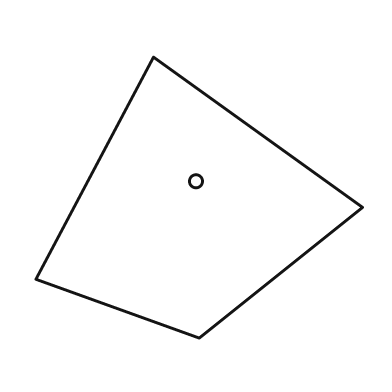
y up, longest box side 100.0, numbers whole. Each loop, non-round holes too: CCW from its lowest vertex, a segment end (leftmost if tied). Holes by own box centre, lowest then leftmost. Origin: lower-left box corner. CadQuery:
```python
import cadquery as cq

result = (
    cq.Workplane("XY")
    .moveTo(50.0, 0.0)
    .lineTo(100.0, 40.0)
    .lineTo(36.0, 86.0)
    .lineTo(0.0, 18.0)
    .close()
    .moveTo(49.0, 48.0)
    .circle(2.0)
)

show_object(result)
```